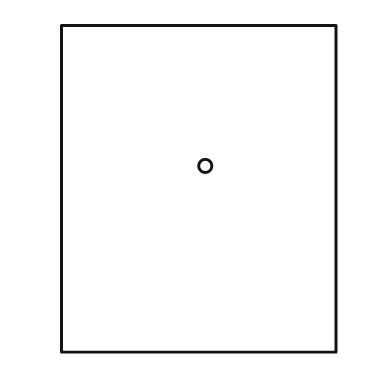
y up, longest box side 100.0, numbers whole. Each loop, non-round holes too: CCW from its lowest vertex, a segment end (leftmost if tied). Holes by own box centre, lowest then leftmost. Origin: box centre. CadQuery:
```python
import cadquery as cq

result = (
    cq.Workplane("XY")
    .moveTo(-42.0, -50.0)
    .lineTo(42.0, -50.0)
    .lineTo(42.0, 50.0)
    .lineTo(-42.0, 50.0)
    .close()
    .moveTo(2.0, 7.0)
    .circle(2.0)
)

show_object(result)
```